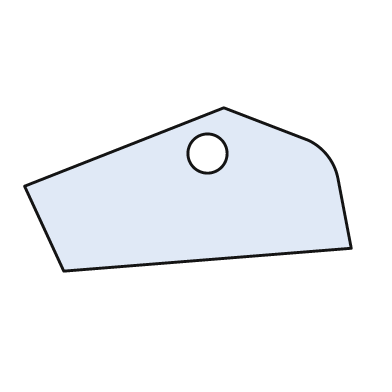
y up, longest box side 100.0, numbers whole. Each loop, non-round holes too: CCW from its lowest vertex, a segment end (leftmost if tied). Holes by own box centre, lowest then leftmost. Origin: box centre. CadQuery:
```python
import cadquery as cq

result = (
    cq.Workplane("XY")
    .moveTo(-38.0, -25.0)
    .lineTo(50.0, -18.0)
    .lineTo(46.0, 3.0)
    .threePointArc((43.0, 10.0), (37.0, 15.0))
    .lineTo(11.0, 25.0)
    .lineTo(-50.0, 1.0)
    .close()
    .moveTo(6.0, 11.0)
    .circle(6.0)
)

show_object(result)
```